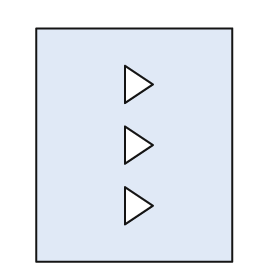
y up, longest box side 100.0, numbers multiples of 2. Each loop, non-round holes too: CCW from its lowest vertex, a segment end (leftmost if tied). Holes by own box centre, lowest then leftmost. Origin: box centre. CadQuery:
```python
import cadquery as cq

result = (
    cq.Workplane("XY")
    .moveTo(-42.0, -50.0)
    .lineTo(42.0, -50.0)
    .lineTo(42.0, 50.0)
    .lineTo(-42.0, 50.0)
    .close()
    .moveTo(-4.0, -34.0)
    .lineTo(8.0, -26.0)
    .lineTo(-4.0, -18.0)
    .close()
    .moveTo(-4.0, -8.0)
    .lineTo(8.0, 0.0)
    .lineTo(-4.0, 8.0)
    .close()
    .moveTo(-4.0, 18.0)
    .lineTo(8.0, 26.0)
    .lineTo(-4.0, 34.0)
    .close()
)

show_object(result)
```